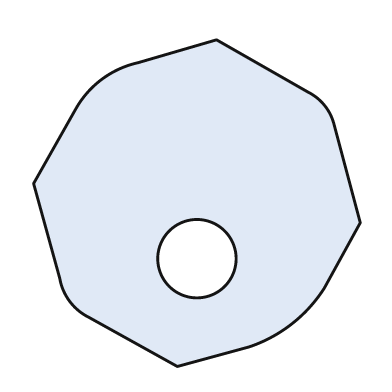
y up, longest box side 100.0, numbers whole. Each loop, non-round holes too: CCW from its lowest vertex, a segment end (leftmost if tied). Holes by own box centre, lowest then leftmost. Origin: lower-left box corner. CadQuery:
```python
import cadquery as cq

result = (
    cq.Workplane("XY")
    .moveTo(44.0, 0.0)
    .lineTo(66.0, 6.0)
    .threePointArc((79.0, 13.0), (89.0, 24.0))
    .lineTo(100.0, 44.0)
    .lineTo(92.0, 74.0)
    .threePointArc((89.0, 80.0), (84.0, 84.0))
    .lineTo(56.0, 100.0)
    .lineTo(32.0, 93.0)
    .threePointArc((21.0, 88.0), (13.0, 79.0))
    .lineTo(0.0, 56.0)
    .lineTo(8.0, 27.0)
    .threePointArc((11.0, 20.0), (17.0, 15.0))
    .close()
    .moveTo(50.0, 33.0)
    .circle(12.0)
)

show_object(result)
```